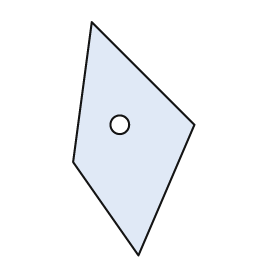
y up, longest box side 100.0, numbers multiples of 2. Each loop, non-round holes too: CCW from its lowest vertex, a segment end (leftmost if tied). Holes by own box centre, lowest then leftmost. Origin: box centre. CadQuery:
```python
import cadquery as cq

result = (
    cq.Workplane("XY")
    .moveTo(2.0, -50.0)
    .lineTo(26.0, 6.0)
    .lineTo(-18.0, 50.0)
    .lineTo(-26.0, -10.0)
    .close()
    .moveTo(-6.0, 6.0)
    .circle(4.0)
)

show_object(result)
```